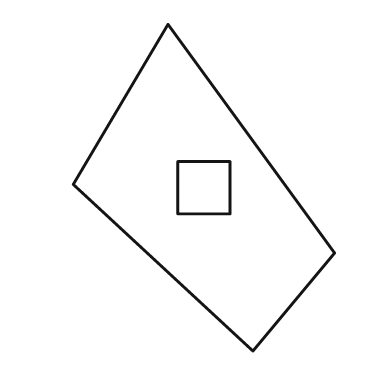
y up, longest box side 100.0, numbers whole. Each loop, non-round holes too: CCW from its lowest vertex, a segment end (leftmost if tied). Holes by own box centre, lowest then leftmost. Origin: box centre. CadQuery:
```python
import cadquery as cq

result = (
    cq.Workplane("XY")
    .moveTo(15.0, -50.0)
    .lineTo(40.0, -20.0)
    .lineTo(-11.0, 50.0)
    .lineTo(-40.0, 1.0)
    .close()
    .moveTo(-8.0, -8.0)
    .lineTo(8.0, -8.0)
    .lineTo(8.0, 8.0)
    .lineTo(-8.0, 8.0)
    .close()
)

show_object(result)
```